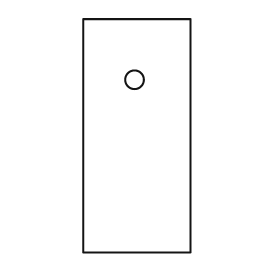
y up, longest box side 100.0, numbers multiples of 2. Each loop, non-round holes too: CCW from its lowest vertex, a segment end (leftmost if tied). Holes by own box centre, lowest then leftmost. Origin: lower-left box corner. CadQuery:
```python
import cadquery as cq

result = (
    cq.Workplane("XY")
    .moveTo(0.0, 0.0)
    .lineTo(46.0, 0.0)
    .lineTo(46.0, 100.0)
    .lineTo(0.0, 100.0)
    .close()
    .moveTo(22.0, 74.0)
    .circle(4.0)
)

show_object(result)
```